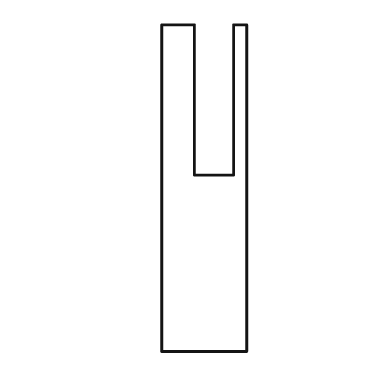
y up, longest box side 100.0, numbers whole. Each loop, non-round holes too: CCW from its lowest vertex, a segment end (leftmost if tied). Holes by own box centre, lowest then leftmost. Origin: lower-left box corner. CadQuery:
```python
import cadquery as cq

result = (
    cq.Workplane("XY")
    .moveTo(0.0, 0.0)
    .lineTo(26.0, 0.0)
    .lineTo(26.0, 100.0)
    .lineTo(22.0, 100.0)
    .lineTo(22.0, 54.0)
    .lineTo(10.0, 54.0)
    .lineTo(10.0, 100.0)
    .lineTo(0.0, 100.0)
    .close()
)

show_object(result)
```